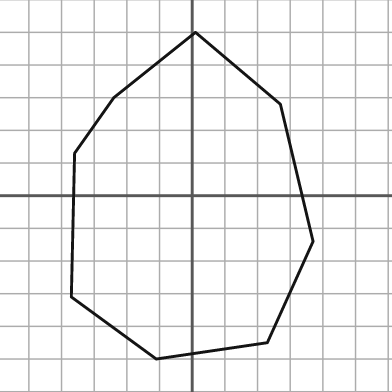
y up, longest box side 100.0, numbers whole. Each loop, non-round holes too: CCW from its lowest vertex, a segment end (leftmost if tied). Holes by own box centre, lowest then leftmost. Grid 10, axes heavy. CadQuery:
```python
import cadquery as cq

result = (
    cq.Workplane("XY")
    .moveTo(-11.0, -50.0)
    .lineTo(23.0, -45.0)
    .lineTo(37.0, -14.0)
    .lineTo(27.0, 28.0)
    .lineTo(1.0, 50.0)
    .lineTo(-24.0, 30.0)
    .lineTo(-36.0, 13.0)
    .lineTo(-37.0, -31.0)
    .close()
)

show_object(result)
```